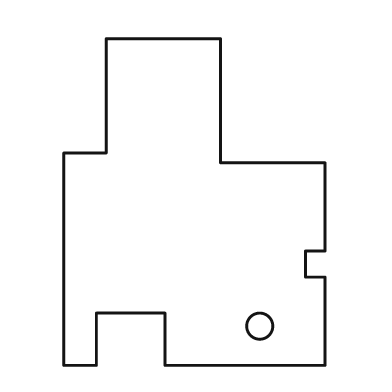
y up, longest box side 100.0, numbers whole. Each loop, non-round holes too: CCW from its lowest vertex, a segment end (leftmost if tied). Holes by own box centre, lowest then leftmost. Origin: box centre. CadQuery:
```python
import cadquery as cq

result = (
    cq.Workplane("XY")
    .moveTo(-40.0, -50.0)
    .lineTo(-30.0, -50.0)
    .lineTo(-30.0, -34.0)
    .lineTo(-9.0, -34.0)
    .lineTo(-9.0, -50.0)
    .lineTo(40.0, -50.0)
    .lineTo(40.0, -23.0)
    .lineTo(34.0, -23.0)
    .lineTo(34.0, -15.0)
    .lineTo(40.0, -15.0)
    .lineTo(40.0, 12.0)
    .lineTo(8.0, 12.0)
    .lineTo(8.0, 50.0)
    .lineTo(-27.0, 50.0)
    .lineTo(-27.0, 15.0)
    .lineTo(-40.0, 15.0)
    .close()
    .moveTo(20.0, -38.0)
    .circle(4.0)
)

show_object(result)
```